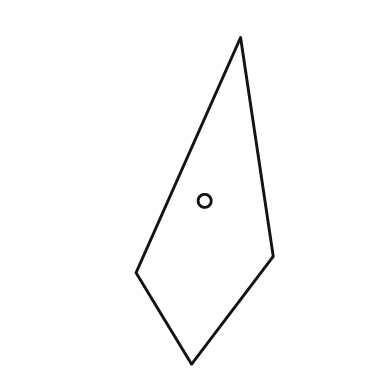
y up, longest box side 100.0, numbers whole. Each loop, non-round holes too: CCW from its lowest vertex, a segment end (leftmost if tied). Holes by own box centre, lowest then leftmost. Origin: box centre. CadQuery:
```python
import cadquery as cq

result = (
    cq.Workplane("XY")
    .moveTo(-4.0, -50.0)
    .lineTo(21.0, -17.0)
    .lineTo(11.0, 50.0)
    .lineTo(-21.0, -22.0)
    .close()
    .moveTo(0.0, 0.0)
    .circle(2.0)
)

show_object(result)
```